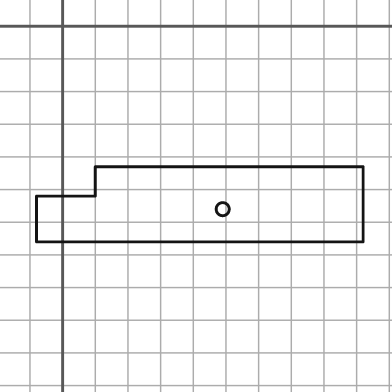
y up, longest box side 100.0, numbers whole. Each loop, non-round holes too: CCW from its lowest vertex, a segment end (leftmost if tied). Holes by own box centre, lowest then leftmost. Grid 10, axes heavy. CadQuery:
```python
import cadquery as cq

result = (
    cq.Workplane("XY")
    .moveTo(-8.0, -66.0)
    .lineTo(92.0, -66.0)
    .lineTo(92.0, -43.0)
    .lineTo(10.0, -43.0)
    .lineTo(10.0, -52.0)
    .lineTo(-8.0, -52.0)
    .close()
    .moveTo(49.0, -56.0)
    .circle(2.0)
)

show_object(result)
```